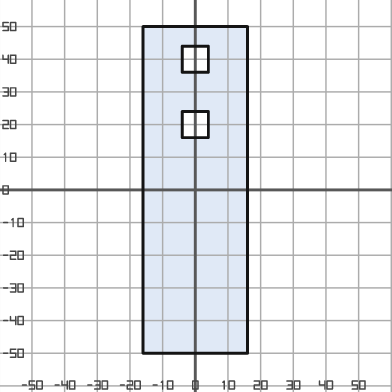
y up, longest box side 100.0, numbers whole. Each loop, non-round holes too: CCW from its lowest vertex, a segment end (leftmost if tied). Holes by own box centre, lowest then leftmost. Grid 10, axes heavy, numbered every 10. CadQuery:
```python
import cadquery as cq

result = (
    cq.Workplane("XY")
    .moveTo(-16.0, -50.0)
    .lineTo(16.0, -50.0)
    .lineTo(16.0, 50.0)
    .lineTo(-16.0, 50.0)
    .close()
    .moveTo(-4.0, 16.0)
    .lineTo(4.0, 16.0)
    .lineTo(4.0, 24.0)
    .lineTo(-4.0, 24.0)
    .close()
    .moveTo(-4.0, 36.0)
    .lineTo(4.0, 36.0)
    .lineTo(4.0, 44.0)
    .lineTo(-4.0, 44.0)
    .close()
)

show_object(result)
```